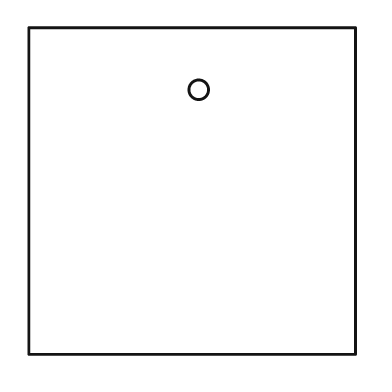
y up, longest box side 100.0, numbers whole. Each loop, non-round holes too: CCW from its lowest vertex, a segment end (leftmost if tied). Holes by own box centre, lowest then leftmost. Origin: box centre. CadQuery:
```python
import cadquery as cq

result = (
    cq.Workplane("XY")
    .moveTo(-50.0, -50.0)
    .lineTo(50.0, -50.0)
    .lineTo(50.0, 50.0)
    .lineTo(-50.0, 50.0)
    .close()
    .moveTo(2.0, 31.0)
    .circle(3.0)
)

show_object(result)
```